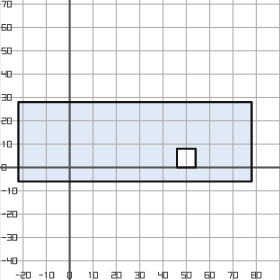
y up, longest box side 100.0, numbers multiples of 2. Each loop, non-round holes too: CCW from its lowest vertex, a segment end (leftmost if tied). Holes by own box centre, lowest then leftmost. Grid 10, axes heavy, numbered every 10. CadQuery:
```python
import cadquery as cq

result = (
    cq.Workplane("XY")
    .moveTo(-22.0, -6.0)
    .lineTo(78.0, -6.0)
    .lineTo(78.0, 28.0)
    .lineTo(-22.0, 28.0)
    .close()
    .moveTo(46.0, 0.0)
    .lineTo(54.0, 0.0)
    .lineTo(54.0, 8.0)
    .lineTo(46.0, 8.0)
    .close()
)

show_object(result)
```